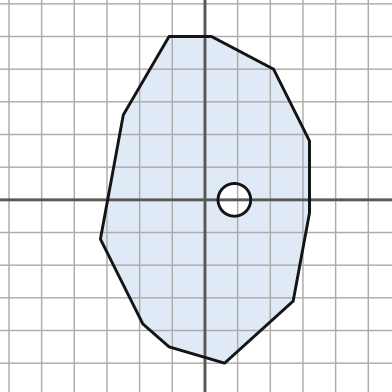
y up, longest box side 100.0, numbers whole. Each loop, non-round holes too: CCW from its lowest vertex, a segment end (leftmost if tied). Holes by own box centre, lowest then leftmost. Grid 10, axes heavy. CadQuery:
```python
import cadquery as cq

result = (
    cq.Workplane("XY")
    .moveTo(6.0, -50.0)
    .lineTo(27.0, -31.0)
    .lineTo(32.0, -4.0)
    .lineTo(32.0, 18.0)
    .lineTo(21.0, 40.0)
    .lineTo(2.0, 50.0)
    .lineTo(-11.0, 50.0)
    .lineTo(-25.0, 26.0)
    .lineTo(-32.0, -12.0)
    .lineTo(-19.0, -38.0)
    .lineTo(-11.0, -45.0)
    .close()
    .moveTo(9.0, 0.0)
    .circle(5.0)
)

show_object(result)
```